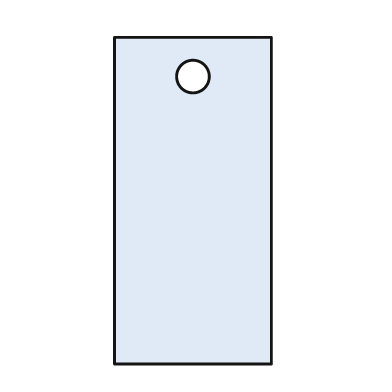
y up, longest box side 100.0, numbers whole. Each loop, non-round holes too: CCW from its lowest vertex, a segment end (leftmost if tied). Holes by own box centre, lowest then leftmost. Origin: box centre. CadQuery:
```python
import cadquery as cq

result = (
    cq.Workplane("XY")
    .moveTo(-24.0, -50.0)
    .lineTo(24.0, -50.0)
    .lineTo(24.0, 50.0)
    .lineTo(-24.0, 50.0)
    .close()
    .moveTo(0.0, 38.0)
    .circle(5.0)
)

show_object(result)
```